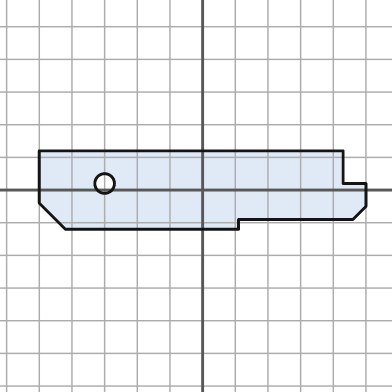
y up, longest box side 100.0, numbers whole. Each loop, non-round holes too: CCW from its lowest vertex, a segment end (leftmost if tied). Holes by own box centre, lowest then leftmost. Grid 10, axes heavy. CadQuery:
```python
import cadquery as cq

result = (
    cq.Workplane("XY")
    .moveTo(-42.0, -12.0)
    .lineTo(11.0, -12.0)
    .lineTo(11.0, -9.0)
    .lineTo(46.0, -9.0)
    .lineTo(50.0, -5.0)
    .lineTo(50.0, 2.0)
    .lineTo(43.0, 2.0)
    .lineTo(43.0, 12.0)
    .lineTo(-50.0, 12.0)
    .lineTo(-50.0, -4.0)
    .close()
    .moveTo(-30.0, 2.0)
    .circle(3.0)
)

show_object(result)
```